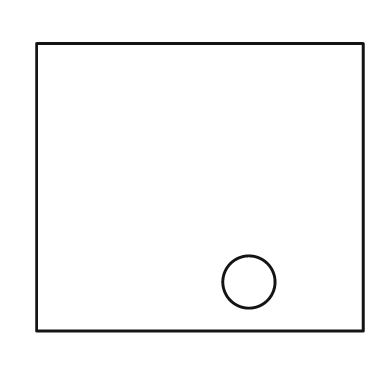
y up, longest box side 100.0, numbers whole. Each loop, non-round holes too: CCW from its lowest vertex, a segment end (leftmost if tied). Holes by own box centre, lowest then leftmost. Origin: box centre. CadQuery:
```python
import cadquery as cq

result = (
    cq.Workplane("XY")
    .moveTo(-50.0, -44.0)
    .lineTo(50.0, -44.0)
    .lineTo(50.0, 44.0)
    .lineTo(-50.0, 44.0)
    .close()
    .moveTo(15.0, -29.0)
    .circle(8.0)
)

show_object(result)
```